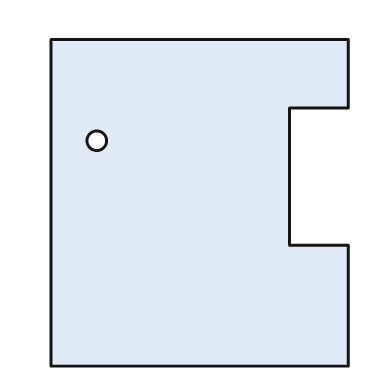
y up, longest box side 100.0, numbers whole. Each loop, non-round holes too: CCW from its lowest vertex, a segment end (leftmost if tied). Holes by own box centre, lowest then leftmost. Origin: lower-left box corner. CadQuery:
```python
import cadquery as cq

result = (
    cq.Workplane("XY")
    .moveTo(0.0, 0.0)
    .lineTo(91.0, 0.0)
    .lineTo(91.0, 37.0)
    .lineTo(73.0, 37.0)
    .lineTo(73.0, 79.0)
    .lineTo(91.0, 79.0)
    .lineTo(91.0, 100.0)
    .lineTo(0.0, 100.0)
    .close()
    .moveTo(14.0, 69.0)
    .circle(3.0)
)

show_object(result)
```